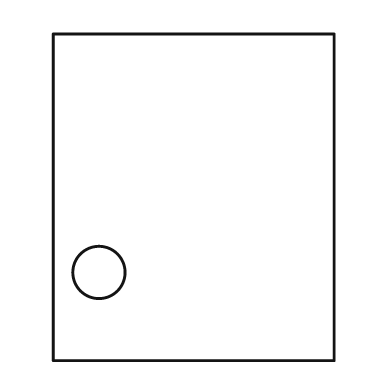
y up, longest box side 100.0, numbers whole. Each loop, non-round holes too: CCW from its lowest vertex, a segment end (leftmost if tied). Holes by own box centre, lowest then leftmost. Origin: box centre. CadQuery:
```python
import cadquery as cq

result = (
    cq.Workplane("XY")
    .moveTo(-43.0, -50.0)
    .lineTo(43.0, -50.0)
    .lineTo(43.0, 50.0)
    .lineTo(-43.0, 50.0)
    .close()
    .moveTo(-29.0, -23.0)
    .circle(8.0)
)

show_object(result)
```